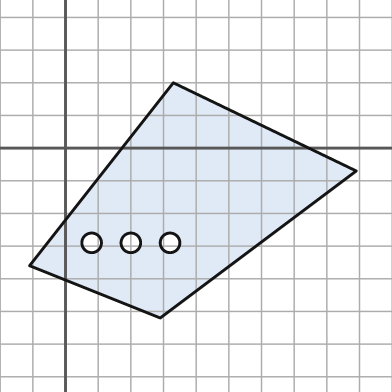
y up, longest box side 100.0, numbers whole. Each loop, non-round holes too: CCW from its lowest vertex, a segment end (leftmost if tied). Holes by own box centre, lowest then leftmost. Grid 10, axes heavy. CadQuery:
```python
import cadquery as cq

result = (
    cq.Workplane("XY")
    .moveTo(29.0, -52.0)
    .lineTo(89.0, -7.0)
    .lineTo(33.0, 20.0)
    .lineTo(-11.0, -36.0)
    .close()
    .moveTo(8.0, -29.0)
    .circle(3.0)
    .moveTo(20.0, -29.0)
    .circle(3.0)
    .moveTo(32.0, -29.0)
    .circle(3.0)
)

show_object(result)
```